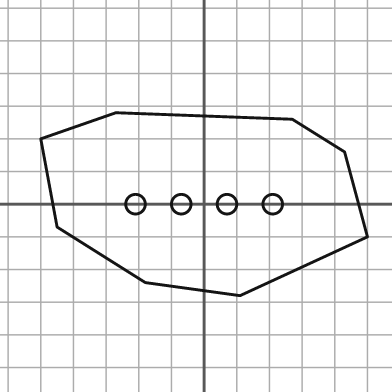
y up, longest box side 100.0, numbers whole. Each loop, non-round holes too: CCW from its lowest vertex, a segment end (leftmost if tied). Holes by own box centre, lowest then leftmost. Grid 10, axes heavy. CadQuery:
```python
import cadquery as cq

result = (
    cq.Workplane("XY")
    .moveTo(11.0, -28.0)
    .lineTo(50.0, -10.0)
    .lineTo(43.0, 16.0)
    .lineTo(27.0, 26.0)
    .lineTo(-27.0, 28.0)
    .lineTo(-50.0, 20.0)
    .lineTo(-45.0, -7.0)
    .lineTo(-18.0, -24.0)
    .close()
    .moveTo(-21.0, 0.0)
    .circle(3.0)
    .moveTo(-7.0, 0.0)
    .circle(3.0)
    .moveTo(7.0, 0.0)
    .circle(3.0)
    .moveTo(21.0, 0.0)
    .circle(3.0)
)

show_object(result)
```